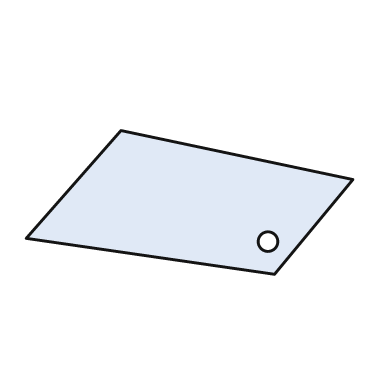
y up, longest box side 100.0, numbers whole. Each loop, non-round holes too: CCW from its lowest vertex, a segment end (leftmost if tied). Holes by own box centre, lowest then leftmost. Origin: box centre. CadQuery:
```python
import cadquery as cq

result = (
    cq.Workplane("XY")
    .moveTo(26.0, -22.0)
    .lineTo(50.0, 7.0)
    .lineTo(-21.0, 22.0)
    .lineTo(-50.0, -11.0)
    .close()
    .moveTo(24.0, -12.0)
    .circle(3.0)
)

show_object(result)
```